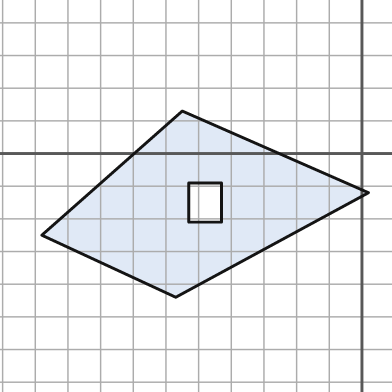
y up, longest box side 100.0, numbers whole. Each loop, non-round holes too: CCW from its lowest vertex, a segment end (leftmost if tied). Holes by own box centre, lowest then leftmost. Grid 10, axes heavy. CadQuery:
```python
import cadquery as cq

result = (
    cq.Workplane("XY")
    .moveTo(-57.0, -44.0)
    .lineTo(2.0, -12.0)
    .lineTo(-55.0, 13.0)
    .lineTo(-98.0, -25.0)
    .close()
    .moveTo(-53.0, -21.0)
    .lineTo(-43.0, -21.0)
    .lineTo(-43.0, -9.0)
    .lineTo(-53.0, -9.0)
    .close()
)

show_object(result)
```